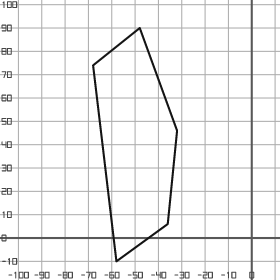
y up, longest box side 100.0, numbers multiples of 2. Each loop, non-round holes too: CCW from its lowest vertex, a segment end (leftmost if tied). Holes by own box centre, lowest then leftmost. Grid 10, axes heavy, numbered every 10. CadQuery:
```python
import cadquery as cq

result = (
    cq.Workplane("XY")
    .moveTo(-58.0, -10.0)
    .lineTo(-36.0, 6.0)
    .lineTo(-32.0, 46.0)
    .lineTo(-48.0, 90.0)
    .lineTo(-68.0, 74.0)
    .close()
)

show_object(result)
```